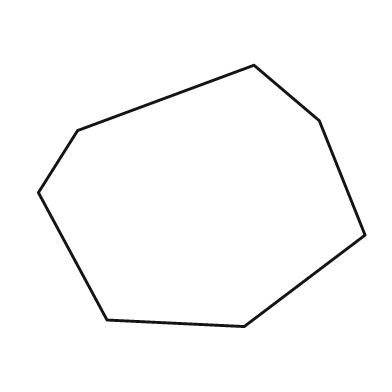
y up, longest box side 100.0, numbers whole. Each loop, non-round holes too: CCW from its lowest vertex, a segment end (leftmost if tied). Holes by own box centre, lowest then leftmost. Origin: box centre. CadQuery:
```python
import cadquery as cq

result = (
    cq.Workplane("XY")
    .moveTo(13.0, -40.0)
    .lineTo(50.0, -12.0)
    .lineTo(36.0, 23.0)
    .lineTo(16.0, 40.0)
    .lineTo(-38.0, 20.0)
    .lineTo(-50.0, 1.0)
    .lineTo(-29.0, -38.0)
    .close()
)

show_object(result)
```